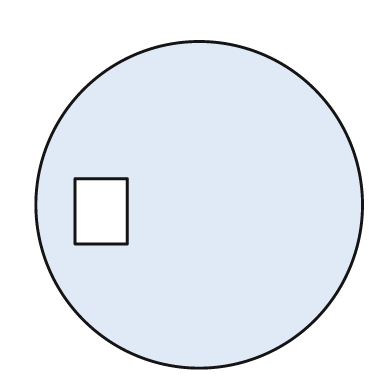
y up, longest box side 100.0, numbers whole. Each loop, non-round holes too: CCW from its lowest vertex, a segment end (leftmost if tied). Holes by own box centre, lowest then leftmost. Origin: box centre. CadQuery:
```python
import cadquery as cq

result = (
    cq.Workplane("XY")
    .moveTo(0.0, 0.0)
    .circle(50.0)
    .moveTo(-38.0, -12.0)
    .lineTo(-22.0, -12.0)
    .lineTo(-22.0, 8.0)
    .lineTo(-38.0, 8.0)
    .close()
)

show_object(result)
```